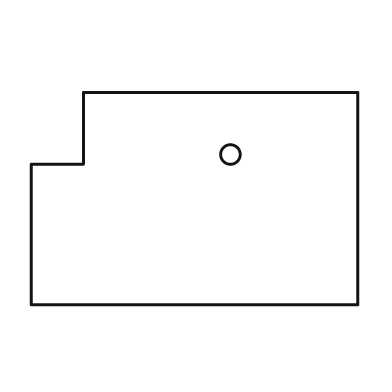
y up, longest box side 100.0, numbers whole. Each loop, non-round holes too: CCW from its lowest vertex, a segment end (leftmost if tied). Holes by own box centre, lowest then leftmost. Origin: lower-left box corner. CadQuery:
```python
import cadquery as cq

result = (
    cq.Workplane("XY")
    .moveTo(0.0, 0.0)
    .lineTo(100.0, 0.0)
    .lineTo(100.0, 65.0)
    .lineTo(16.0, 65.0)
    .lineTo(16.0, 43.0)
    .lineTo(0.0, 43.0)
    .close()
    .moveTo(61.0, 46.0)
    .circle(3.0)
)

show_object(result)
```